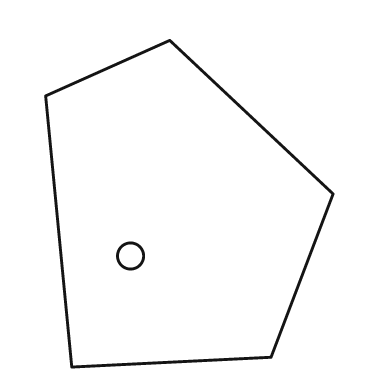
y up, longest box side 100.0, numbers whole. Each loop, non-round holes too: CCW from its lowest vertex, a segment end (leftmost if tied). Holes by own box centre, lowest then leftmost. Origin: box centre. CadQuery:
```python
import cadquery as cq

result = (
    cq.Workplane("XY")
    .moveTo(-36.0, -50.0)
    .lineTo(25.0, -47.0)
    .lineTo(44.0, 3.0)
    .lineTo(-6.0, 50.0)
    .lineTo(-44.0, 33.0)
    .close()
    .moveTo(-18.0, -16.0)
    .circle(4.0)
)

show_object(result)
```